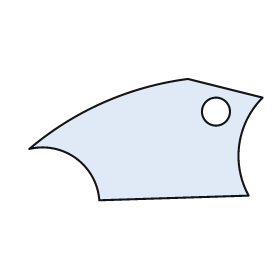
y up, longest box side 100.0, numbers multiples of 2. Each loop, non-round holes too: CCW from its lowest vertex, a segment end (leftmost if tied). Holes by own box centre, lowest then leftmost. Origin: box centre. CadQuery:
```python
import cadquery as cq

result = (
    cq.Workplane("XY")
    .moveTo(-20.0, -26.0)
    .lineTo(44.0, -24.0)
    .threePointArc((40.0, -2.0), (50.0, 18.0))
    .lineTo(18.0, 26.0)
    .threePointArc((-18.0, 16.0), (-50.0, -4.0))
    .threePointArc((-30.0, -8.0), (-20.0, -26.0))
    .close()
    .moveTo(30.0, 12.0)
    .circle(6.0)
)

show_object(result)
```